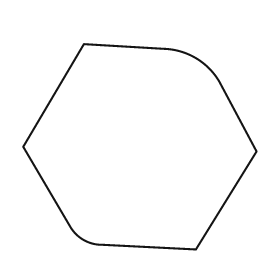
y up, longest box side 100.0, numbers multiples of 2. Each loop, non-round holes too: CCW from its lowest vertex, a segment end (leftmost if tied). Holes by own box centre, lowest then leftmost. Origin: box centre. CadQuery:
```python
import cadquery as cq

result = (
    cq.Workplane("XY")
    .moveTo(24.0, -44.0)
    .lineTo(50.0, -2.0)
    .lineTo(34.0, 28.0)
    .threePointArc((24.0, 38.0), (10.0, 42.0))
    .lineTo(-24.0, 44.0)
    .lineTo(-50.0, 0.0)
    .lineTo(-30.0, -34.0)
    .threePointArc((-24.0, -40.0), (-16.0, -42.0))
    .close()
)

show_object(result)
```